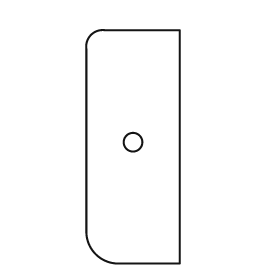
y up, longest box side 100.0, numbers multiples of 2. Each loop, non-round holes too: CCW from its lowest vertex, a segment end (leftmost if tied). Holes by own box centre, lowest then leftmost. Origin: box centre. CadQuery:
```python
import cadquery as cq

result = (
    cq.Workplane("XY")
    .moveTo(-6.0, -50.0)
    .lineTo(20.0, -50.0)
    .lineTo(20.0, 50.0)
    .lineTo(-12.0, 50.0)
    .threePointArc((-18.0, 48.0), (-20.0, 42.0))
    .lineTo(-20.0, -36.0)
    .threePointArc((-16.0, -46.0), (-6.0, -50.0))
    .close()
    .moveTo(0.0, 2.0)
    .circle(4.0)
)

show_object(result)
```